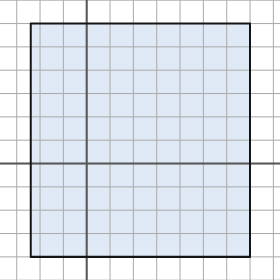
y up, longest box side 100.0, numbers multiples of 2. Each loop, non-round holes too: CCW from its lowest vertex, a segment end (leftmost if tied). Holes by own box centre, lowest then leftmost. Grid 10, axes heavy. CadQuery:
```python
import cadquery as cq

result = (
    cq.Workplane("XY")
    .moveTo(-24.0, -40.0)
    .lineTo(70.0, -40.0)
    .lineTo(70.0, 60.0)
    .lineTo(-24.0, 60.0)
    .close()
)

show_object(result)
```